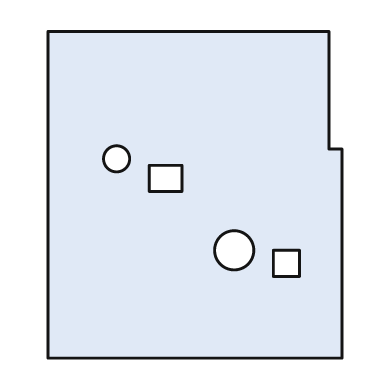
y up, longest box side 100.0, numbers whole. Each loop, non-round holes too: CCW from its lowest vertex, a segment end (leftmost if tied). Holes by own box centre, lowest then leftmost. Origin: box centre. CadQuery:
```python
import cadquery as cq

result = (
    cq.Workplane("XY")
    .moveTo(-45.0, -50.0)
    .lineTo(45.0, -50.0)
    .lineTo(45.0, 14.0)
    .lineTo(41.0, 14.0)
    .lineTo(41.0, 50.0)
    .lineTo(-45.0, 50.0)
    .close()
    .moveTo(24.0, -25.0)
    .lineTo(32.0, -25.0)
    .lineTo(32.0, -17.0)
    .lineTo(24.0, -17.0)
    .close()
    .moveTo(12.0, -17.0)
    .circle(6.0)
    .moveTo(-14.0, 1.0)
    .lineTo(-4.0, 1.0)
    .lineTo(-4.0, 9.0)
    .lineTo(-14.0, 9.0)
    .close()
    .moveTo(-24.0, 11.0)
    .circle(4.0)
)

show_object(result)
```